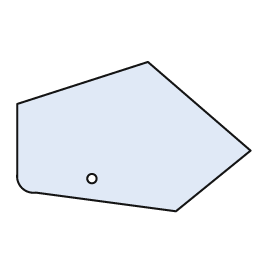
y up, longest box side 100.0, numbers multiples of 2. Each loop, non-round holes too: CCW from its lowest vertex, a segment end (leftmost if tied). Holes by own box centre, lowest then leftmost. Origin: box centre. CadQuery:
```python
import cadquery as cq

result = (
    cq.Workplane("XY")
    .moveTo(18.0, -32.0)
    .lineTo(50.0, -6.0)
    .lineTo(6.0, 32.0)
    .lineTo(-50.0, 14.0)
    .lineTo(-50.0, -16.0)
    .threePointArc((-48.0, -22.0), (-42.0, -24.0))
    .close()
    .moveTo(-18.0, -18.0)
    .circle(2.0)
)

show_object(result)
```